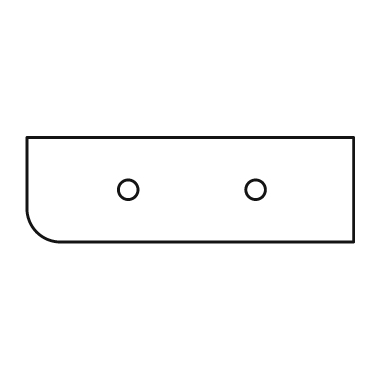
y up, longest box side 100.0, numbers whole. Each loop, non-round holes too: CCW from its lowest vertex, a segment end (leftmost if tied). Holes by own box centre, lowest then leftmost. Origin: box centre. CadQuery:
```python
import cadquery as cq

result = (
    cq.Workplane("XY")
    .moveTo(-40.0, -16.0)
    .lineTo(50.0, -16.0)
    .lineTo(50.0, 16.0)
    .lineTo(-50.0, 16.0)
    .lineTo(-50.0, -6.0)
    .threePointArc((-47.0, -13.0), (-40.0, -16.0))
    .close()
    .moveTo(-19.0, 0.0)
    .circle(3.0)
    .moveTo(20.0, 0.0)
    .circle(3.0)
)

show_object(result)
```